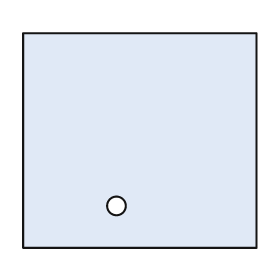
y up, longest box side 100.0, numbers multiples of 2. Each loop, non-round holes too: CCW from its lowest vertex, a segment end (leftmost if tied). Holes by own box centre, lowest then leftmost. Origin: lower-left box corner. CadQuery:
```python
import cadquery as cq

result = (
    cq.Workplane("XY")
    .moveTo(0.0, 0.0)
    .lineTo(100.0, 0.0)
    .lineTo(100.0, 92.0)
    .lineTo(0.0, 92.0)
    .close()
    .moveTo(40.0, 18.0)
    .circle(4.0)
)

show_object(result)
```